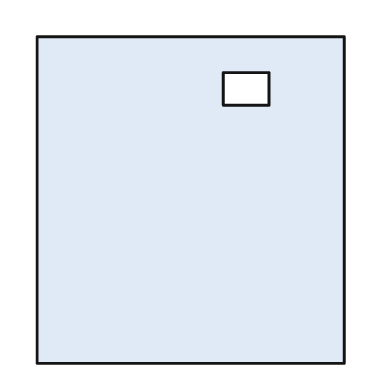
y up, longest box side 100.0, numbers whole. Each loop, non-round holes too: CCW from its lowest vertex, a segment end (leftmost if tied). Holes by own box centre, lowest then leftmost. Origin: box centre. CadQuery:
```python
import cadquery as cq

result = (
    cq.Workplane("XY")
    .moveTo(-47.0, -50.0)
    .lineTo(47.0, -50.0)
    .lineTo(47.0, 50.0)
    .lineTo(-47.0, 50.0)
    .close()
    .moveTo(10.0, 29.0)
    .lineTo(24.0, 29.0)
    .lineTo(24.0, 39.0)
    .lineTo(10.0, 39.0)
    .close()
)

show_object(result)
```